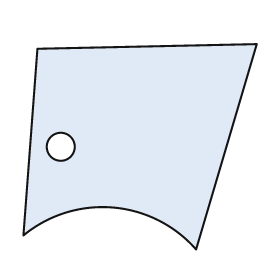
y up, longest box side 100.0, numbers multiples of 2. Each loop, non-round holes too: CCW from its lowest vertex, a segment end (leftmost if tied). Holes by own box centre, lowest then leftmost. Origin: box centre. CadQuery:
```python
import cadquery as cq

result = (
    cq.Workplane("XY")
    .moveTo(24.0, -44.0)
    .lineTo(50.0, 44.0)
    .lineTo(-44.0, 42.0)
    .lineTo(-50.0, -38.0)
    .threePointArc((-12.0, -26.0), (24.0, -44.0))
    .close()
    .moveTo(-34.0, 0.0)
    .circle(6.0)
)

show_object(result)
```